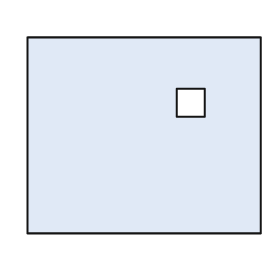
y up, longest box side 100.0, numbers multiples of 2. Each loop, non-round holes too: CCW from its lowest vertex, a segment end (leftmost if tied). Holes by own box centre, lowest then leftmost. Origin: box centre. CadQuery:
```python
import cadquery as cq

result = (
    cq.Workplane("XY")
    .moveTo(-50.0, -42.0)
    .lineTo(50.0, -42.0)
    .lineTo(50.0, 42.0)
    .lineTo(-50.0, 42.0)
    .close()
    .moveTo(14.0, 8.0)
    .lineTo(26.0, 8.0)
    .lineTo(26.0, 20.0)
    .lineTo(14.0, 20.0)
    .close()
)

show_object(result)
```